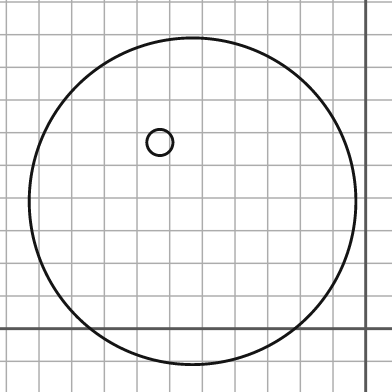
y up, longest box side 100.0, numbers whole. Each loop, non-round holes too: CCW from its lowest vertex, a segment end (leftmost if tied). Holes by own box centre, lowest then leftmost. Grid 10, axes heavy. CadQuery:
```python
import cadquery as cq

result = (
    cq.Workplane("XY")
    .moveTo(-53.0, 39.0)
    .circle(50.0)
    .moveTo(-63.0, 57.0)
    .circle(4.0)
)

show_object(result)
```